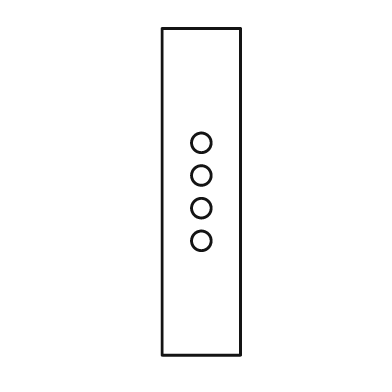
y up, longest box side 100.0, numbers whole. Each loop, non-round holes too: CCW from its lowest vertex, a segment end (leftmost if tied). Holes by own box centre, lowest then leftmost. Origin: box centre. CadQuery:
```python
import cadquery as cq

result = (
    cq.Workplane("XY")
    .moveTo(-12.0, -50.0)
    .lineTo(12.0, -50.0)
    .lineTo(12.0, 50.0)
    .lineTo(-12.0, 50.0)
    .close()
    .moveTo(0.0, -15.0)
    .circle(3.0)
    .moveTo(0.0, -5.0)
    .circle(3.0)
    .moveTo(0.0, 5.0)
    .circle(3.0)
    .moveTo(0.0, 15.0)
    .circle(3.0)
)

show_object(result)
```